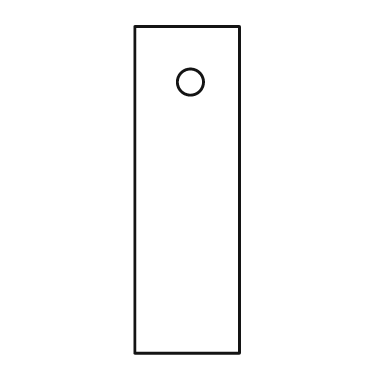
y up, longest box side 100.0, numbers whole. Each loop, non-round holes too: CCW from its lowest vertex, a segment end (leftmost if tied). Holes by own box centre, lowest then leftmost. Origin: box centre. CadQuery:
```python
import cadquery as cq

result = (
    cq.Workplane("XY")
    .moveTo(-16.0, -50.0)
    .lineTo(16.0, -50.0)
    .lineTo(16.0, 50.0)
    .lineTo(-16.0, 50.0)
    .close()
    .moveTo(1.0, 33.0)
    .circle(4.0)
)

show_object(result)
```